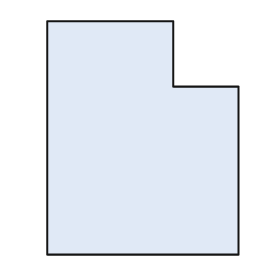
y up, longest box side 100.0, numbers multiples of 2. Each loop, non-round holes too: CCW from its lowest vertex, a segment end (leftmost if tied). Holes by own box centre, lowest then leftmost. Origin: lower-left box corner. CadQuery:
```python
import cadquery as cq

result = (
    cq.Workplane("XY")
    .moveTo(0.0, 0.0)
    .lineTo(82.0, 0.0)
    .lineTo(82.0, 72.0)
    .lineTo(54.0, 72.0)
    .lineTo(54.0, 100.0)
    .lineTo(0.0, 100.0)
    .close()
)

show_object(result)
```